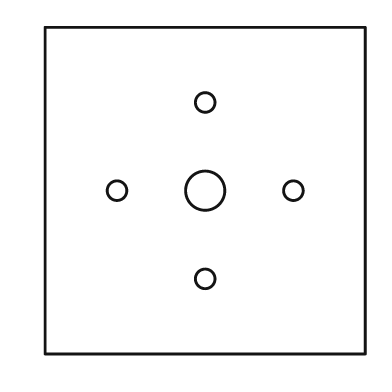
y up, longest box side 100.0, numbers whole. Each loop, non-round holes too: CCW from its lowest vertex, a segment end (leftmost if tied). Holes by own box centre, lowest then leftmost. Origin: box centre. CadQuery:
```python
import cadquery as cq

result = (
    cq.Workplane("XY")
    .moveTo(-49.0, -50.0)
    .lineTo(49.0, -50.0)
    .lineTo(49.0, 50.0)
    .lineTo(-49.0, 50.0)
    .close()
    .moveTo(0.0, -27.0)
    .circle(3.0)
    .moveTo(-27.0, 0.0)
    .circle(3.0)
    .moveTo(0.0, 0.0)
    .circle(6.0)
    .moveTo(27.0, 0.0)
    .circle(3.0)
    .moveTo(0.0, 27.0)
    .circle(3.0)
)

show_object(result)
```